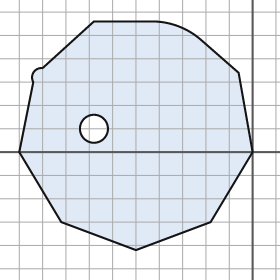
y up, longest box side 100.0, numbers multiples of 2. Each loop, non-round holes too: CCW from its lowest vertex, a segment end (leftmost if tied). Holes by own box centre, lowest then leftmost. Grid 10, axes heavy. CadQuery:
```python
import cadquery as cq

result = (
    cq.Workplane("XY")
    .moveTo(-50.0, -42.0)
    .lineTo(-18.0, -30.0)
    .lineTo(0.0, 0.0)
    .lineTo(-6.0, 34.0)
    .lineTo(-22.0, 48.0)
    .threePointArc((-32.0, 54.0), (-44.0, 56.0))
    .lineTo(-68.0, 56.0)
    .lineTo(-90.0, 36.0)
    .threePointArc((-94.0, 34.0), (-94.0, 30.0))
    .lineTo(-100.0, 0.0)
    .lineTo(-82.0, -30.0)
    .close()
    .moveTo(-68.0, 10.0)
    .circle(6.0)
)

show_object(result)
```